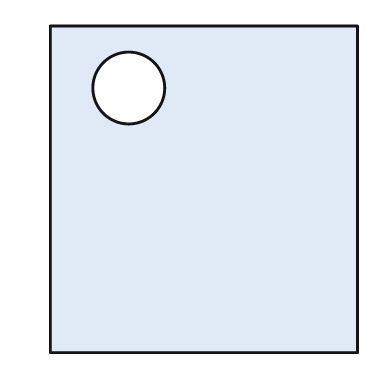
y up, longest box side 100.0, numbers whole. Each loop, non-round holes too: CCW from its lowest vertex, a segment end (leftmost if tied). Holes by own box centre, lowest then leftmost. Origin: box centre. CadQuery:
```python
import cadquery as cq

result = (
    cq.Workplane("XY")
    .moveTo(-47.0, -50.0)
    .lineTo(47.0, -50.0)
    .lineTo(47.0, 50.0)
    .lineTo(-47.0, 50.0)
    .close()
    .moveTo(-23.0, 31.0)
    .circle(11.0)
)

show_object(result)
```